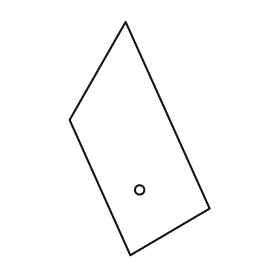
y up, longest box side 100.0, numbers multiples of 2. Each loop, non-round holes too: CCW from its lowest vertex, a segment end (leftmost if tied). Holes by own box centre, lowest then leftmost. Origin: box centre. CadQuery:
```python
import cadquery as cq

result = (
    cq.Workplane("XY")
    .moveTo(-4.0, -50.0)
    .lineTo(30.0, -30.0)
    .lineTo(-6.0, 50.0)
    .lineTo(-30.0, 8.0)
    .close()
    .moveTo(0.0, -22.0)
    .circle(2.0)
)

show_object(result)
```